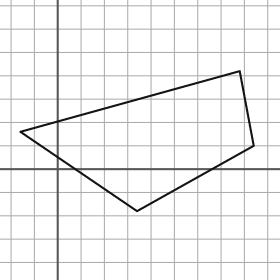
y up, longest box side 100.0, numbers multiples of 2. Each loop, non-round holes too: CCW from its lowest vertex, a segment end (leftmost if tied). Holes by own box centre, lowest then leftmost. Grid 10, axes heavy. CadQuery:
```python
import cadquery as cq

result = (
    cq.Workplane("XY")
    .moveTo(34.0, -18.0)
    .lineTo(84.0, 10.0)
    .lineTo(78.0, 42.0)
    .lineTo(-16.0, 16.0)
    .close()
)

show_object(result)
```